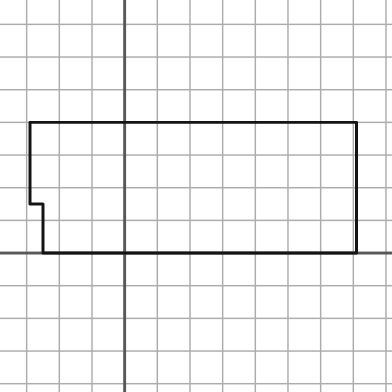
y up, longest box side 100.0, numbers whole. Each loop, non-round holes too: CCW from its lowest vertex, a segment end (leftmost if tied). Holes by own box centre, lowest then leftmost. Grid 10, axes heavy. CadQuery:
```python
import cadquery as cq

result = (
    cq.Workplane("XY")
    .moveTo(-25.0, 0.0)
    .lineTo(71.0, 0.0)
    .lineTo(71.0, 40.0)
    .lineTo(-29.0, 40.0)
    .lineTo(-29.0, 15.0)
    .lineTo(-25.0, 15.0)
    .close()
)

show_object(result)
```